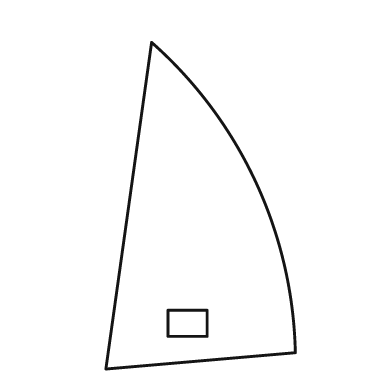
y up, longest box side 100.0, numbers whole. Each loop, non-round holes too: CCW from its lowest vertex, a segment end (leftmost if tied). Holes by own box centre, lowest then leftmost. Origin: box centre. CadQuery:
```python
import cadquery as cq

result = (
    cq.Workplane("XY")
    .moveTo(-29.0, -50.0)
    .lineTo(29.0, -45.0)
    .threePointArc((17.0, 7.0), (-15.0, 50.0))
    .close()
    .moveTo(-10.0, -40.0)
    .lineTo(2.0, -40.0)
    .lineTo(2.0, -32.0)
    .lineTo(-10.0, -32.0)
    .close()
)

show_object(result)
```